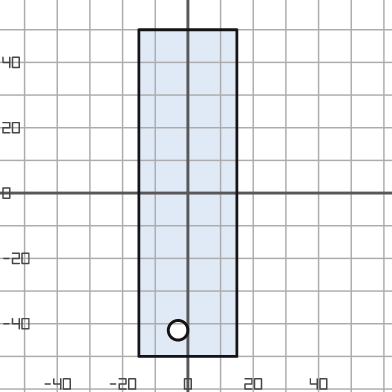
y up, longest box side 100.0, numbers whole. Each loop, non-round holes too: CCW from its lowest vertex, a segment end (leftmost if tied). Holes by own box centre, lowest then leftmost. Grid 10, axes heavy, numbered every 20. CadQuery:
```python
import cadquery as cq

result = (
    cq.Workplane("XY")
    .moveTo(-15.0, -50.0)
    .lineTo(15.0, -50.0)
    .lineTo(15.0, 50.0)
    .lineTo(-15.0, 50.0)
    .close()
    .moveTo(-3.0, -42.0)
    .circle(3.0)
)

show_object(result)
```